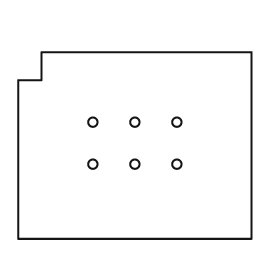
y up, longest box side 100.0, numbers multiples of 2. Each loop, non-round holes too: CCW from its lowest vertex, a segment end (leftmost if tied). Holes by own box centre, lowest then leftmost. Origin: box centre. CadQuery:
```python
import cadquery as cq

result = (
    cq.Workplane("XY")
    .moveTo(-50.0, -40.0)
    .lineTo(50.0, -40.0)
    .lineTo(50.0, 40.0)
    .lineTo(-40.0, 40.0)
    .lineTo(-40.0, 28.0)
    .lineTo(-50.0, 28.0)
    .close()
    .moveTo(-18.0, -8.0)
    .circle(2.0)
    .moveTo(0.0, -8.0)
    .circle(2.0)
    .moveTo(18.0, -8.0)
    .circle(2.0)
    .moveTo(-18.0, 10.0)
    .circle(2.0)
    .moveTo(0.0, 10.0)
    .circle(2.0)
    .moveTo(18.0, 10.0)
    .circle(2.0)
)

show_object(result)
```